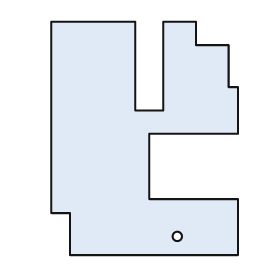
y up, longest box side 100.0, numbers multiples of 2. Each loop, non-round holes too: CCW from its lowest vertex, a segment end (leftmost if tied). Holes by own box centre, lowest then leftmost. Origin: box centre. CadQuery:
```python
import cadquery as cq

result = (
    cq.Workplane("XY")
    .moveTo(-32.0, -50.0)
    .lineTo(40.0, -50.0)
    .lineTo(40.0, -26.0)
    .lineTo(2.0, -26.0)
    .lineTo(2.0, 2.0)
    .lineTo(40.0, 2.0)
    .lineTo(40.0, 22.0)
    .lineTo(36.0, 22.0)
    .lineTo(36.0, 40.0)
    .lineTo(22.0, 40.0)
    .lineTo(22.0, 50.0)
    .lineTo(8.0, 50.0)
    .lineTo(8.0, 12.0)
    .lineTo(-4.0, 12.0)
    .lineTo(-4.0, 50.0)
    .lineTo(-40.0, 50.0)
    .lineTo(-40.0, -32.0)
    .lineTo(-32.0, -32.0)
    .close()
    .moveTo(14.0, -42.0)
    .circle(2.0)
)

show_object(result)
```